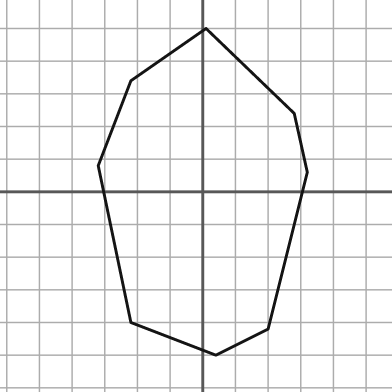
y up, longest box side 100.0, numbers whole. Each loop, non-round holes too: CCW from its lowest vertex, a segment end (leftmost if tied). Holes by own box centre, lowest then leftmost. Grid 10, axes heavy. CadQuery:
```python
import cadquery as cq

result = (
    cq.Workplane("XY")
    .moveTo(4.0, -50.0)
    .lineTo(20.0, -42.0)
    .lineTo(32.0, 6.0)
    .lineTo(28.0, 24.0)
    .lineTo(1.0, 50.0)
    .lineTo(-22.0, 34.0)
    .lineTo(-32.0, 8.0)
    .lineTo(-22.0, -40.0)
    .close()
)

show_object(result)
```